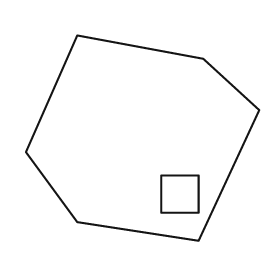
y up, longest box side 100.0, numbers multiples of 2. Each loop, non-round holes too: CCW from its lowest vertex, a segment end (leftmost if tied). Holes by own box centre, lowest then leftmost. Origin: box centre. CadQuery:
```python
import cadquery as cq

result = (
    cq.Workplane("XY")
    .moveTo(24.0, -44.0)
    .lineTo(50.0, 12.0)
    .lineTo(26.0, 34.0)
    .lineTo(-28.0, 44.0)
    .lineTo(-50.0, -6.0)
    .lineTo(-28.0, -36.0)
    .close()
    .moveTo(8.0, -32.0)
    .lineTo(24.0, -32.0)
    .lineTo(24.0, -16.0)
    .lineTo(8.0, -16.0)
    .close()
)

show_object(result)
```